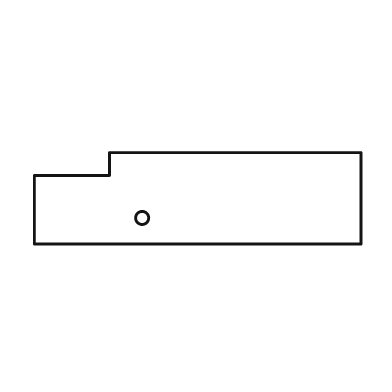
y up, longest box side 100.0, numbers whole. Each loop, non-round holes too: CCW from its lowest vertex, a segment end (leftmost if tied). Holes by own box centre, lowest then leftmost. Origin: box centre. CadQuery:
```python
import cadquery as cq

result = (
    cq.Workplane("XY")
    .moveTo(-50.0, -14.0)
    .lineTo(50.0, -14.0)
    .lineTo(50.0, 14.0)
    .lineTo(-27.0, 14.0)
    .lineTo(-27.0, 7.0)
    .lineTo(-50.0, 7.0)
    .close()
    .moveTo(-17.0, -6.0)
    .circle(2.0)
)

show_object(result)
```